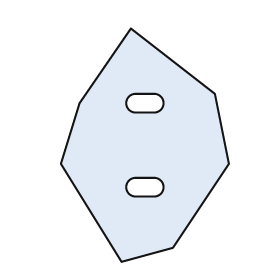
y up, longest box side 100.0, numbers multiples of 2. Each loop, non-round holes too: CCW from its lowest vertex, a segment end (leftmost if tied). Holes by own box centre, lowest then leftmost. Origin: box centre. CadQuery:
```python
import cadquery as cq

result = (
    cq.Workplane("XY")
    .moveTo(-10.0, -50.0)
    .lineTo(12.0, -44.0)
    .lineTo(36.0, -8.0)
    .lineTo(30.0, 22.0)
    .lineTo(-6.0, 50.0)
    .lineTo(-28.0, 18.0)
    .lineTo(-36.0, -8.0)
    .close()
    .moveTo(-4.0, -22.0)
    .lineTo(4.0, -22.0)
    .threePointArc((8.0, -18.0), (4.0, -14.0))
    .lineTo(-4.0, -14.0)
    .threePointArc((-8.0, -18.0), (-4.0, -22.0))
    .close()
    .moveTo(-4.0, 14.0)
    .lineTo(4.0, 14.0)
    .threePointArc((8.0, 18.0), (4.0, 22.0))
    .lineTo(-4.0, 22.0)
    .threePointArc((-8.0, 18.0), (-4.0, 14.0))
    .close()
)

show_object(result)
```